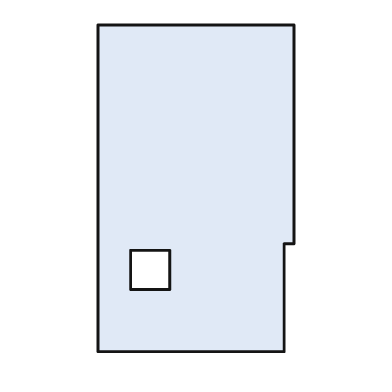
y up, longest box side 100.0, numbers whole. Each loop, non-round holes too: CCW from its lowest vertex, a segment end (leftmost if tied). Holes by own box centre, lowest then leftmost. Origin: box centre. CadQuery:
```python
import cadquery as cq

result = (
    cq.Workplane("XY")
    .moveTo(-30.0, -50.0)
    .lineTo(27.0, -50.0)
    .lineTo(27.0, -17.0)
    .lineTo(30.0, -17.0)
    .lineTo(30.0, 50.0)
    .lineTo(-30.0, 50.0)
    .close()
    .moveTo(-20.0, -31.0)
    .lineTo(-8.0, -31.0)
    .lineTo(-8.0, -19.0)
    .lineTo(-20.0, -19.0)
    .close()
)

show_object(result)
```